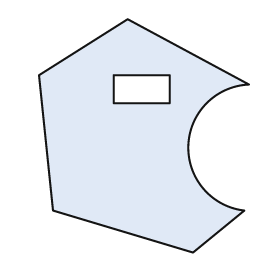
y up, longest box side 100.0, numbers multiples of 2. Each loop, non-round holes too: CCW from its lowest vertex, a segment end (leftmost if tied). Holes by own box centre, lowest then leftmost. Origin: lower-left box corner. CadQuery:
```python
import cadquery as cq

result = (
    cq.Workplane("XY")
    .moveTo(66.0, 0.0)
    .lineTo(88.0, 18.0)
    .threePointArc((64.0, 46.0), (90.0, 72.0))
    .lineTo(38.0, 100.0)
    .lineTo(0.0, 76.0)
    .lineTo(6.0, 18.0)
    .close()
    .moveTo(32.0, 64.0)
    .lineTo(56.0, 64.0)
    .lineTo(56.0, 76.0)
    .lineTo(32.0, 76.0)
    .close()
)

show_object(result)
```